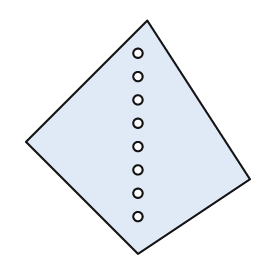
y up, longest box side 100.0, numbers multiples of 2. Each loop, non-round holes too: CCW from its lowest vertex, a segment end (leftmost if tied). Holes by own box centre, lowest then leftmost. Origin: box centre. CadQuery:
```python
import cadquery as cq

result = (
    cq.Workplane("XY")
    .moveTo(0.0, -50.0)
    .lineTo(48.0, -18.0)
    .lineTo(4.0, 50.0)
    .lineTo(-48.0, -2.0)
    .close()
    .moveTo(0.0, -34.0)
    .circle(2.0)
    .moveTo(0.0, -24.0)
    .circle(2.0)
    .moveTo(0.0, -14.0)
    .circle(2.0)
    .moveTo(0.0, -4.0)
    .circle(2.0)
    .moveTo(0.0, 6.0)
    .circle(2.0)
    .moveTo(0.0, 16.0)
    .circle(2.0)
    .moveTo(0.0, 26.0)
    .circle(2.0)
    .moveTo(0.0, 36.0)
    .circle(2.0)
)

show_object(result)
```